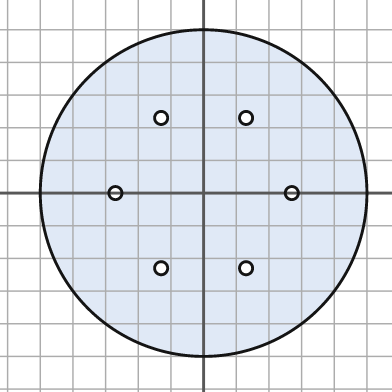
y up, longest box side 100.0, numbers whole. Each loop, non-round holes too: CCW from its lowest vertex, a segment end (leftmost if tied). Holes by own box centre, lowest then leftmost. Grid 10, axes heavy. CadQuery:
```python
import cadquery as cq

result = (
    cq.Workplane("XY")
    .moveTo(0.0, 0.0)
    .circle(50.0)
    .moveTo(-13.0, -23.0)
    .circle(2.0)
    .moveTo(13.0, -23.0)
    .circle(2.0)
    .moveTo(-27.0, 0.0)
    .circle(2.0)
    .moveTo(27.0, 0.0)
    .circle(2.0)
    .moveTo(-13.0, 23.0)
    .circle(2.0)
    .moveTo(13.0, 23.0)
    .circle(2.0)
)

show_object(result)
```